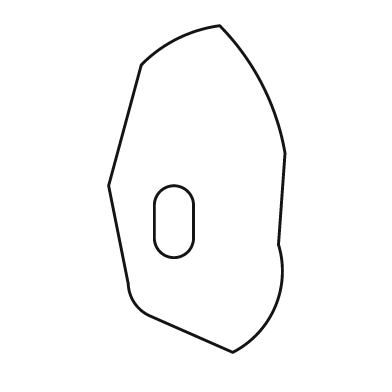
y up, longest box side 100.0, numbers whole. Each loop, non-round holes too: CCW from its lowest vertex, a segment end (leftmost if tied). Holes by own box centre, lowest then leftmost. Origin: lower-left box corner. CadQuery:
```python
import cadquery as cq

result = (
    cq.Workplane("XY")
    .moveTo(38.0, 0.0)
    .threePointArc((51.0, 14.0), (52.0, 33.0))
    .lineTo(54.0, 61.0)
    .threePointArc((47.0, 82.0), (34.0, 100.0))
    .threePointArc((21.0, 96.0), (10.0, 88.0))
    .lineTo(0.0, 51.0)
    .lineTo(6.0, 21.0)
    .threePointArc((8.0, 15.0), (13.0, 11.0))
    .close()
    .moveTo(14.0, 35.0)
    .threePointArc((20.0, 29.0), (26.0, 35.0))
    .lineTo(26.0, 45.0)
    .threePointArc((20.0, 51.0), (14.0, 45.0))
    .close()
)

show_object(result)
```